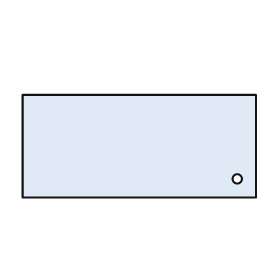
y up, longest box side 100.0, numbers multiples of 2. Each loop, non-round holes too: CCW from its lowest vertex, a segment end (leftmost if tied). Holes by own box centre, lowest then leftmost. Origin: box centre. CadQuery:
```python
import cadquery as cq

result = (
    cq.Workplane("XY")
    .moveTo(-50.0, -22.0)
    .lineTo(50.0, -22.0)
    .lineTo(50.0, 22.0)
    .lineTo(-50.0, 22.0)
    .close()
    .moveTo(42.0, -14.0)
    .circle(2.0)
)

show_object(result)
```